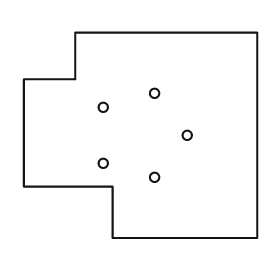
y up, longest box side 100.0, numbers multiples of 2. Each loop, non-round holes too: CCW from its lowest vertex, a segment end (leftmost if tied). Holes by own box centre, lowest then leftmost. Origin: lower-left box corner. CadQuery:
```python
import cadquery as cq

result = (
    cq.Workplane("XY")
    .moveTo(38.0, 0.0)
    .lineTo(100.0, 0.0)
    .lineTo(100.0, 88.0)
    .lineTo(22.0, 88.0)
    .lineTo(22.0, 68.0)
    .lineTo(0.0, 68.0)
    .lineTo(0.0, 22.0)
    .lineTo(38.0, 22.0)
    .close()
    .moveTo(56.0, 26.0)
    .circle(2.0)
    .moveTo(34.0, 32.0)
    .circle(2.0)
    .moveTo(70.0, 44.0)
    .circle(2.0)
    .moveTo(34.0, 56.0)
    .circle(2.0)
    .moveTo(56.0, 62.0)
    .circle(2.0)
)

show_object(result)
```